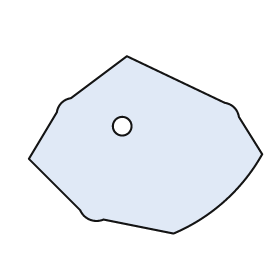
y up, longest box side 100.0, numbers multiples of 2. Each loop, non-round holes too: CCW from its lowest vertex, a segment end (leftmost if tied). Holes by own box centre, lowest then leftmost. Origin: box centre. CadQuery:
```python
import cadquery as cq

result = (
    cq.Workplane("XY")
    .moveTo(12.0, -38.0)
    .threePointArc((34.0, -24.0), (50.0, -4.0))
    .lineTo(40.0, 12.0)
    .threePointArc((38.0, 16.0), (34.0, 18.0))
    .lineTo(-8.0, 38.0)
    .lineTo(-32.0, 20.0)
    .threePointArc((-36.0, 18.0), (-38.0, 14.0))
    .lineTo(-50.0, -6.0)
    .lineTo(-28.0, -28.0)
    .threePointArc((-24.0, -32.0), (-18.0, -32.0))
    .close()
    .moveTo(-10.0, 8.0)
    .circle(4.0)
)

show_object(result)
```